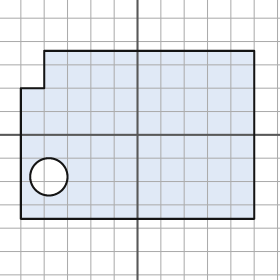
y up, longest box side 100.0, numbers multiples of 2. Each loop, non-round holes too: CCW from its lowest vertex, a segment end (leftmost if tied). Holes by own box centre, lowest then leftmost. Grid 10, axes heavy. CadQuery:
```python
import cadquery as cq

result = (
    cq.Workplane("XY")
    .moveTo(-50.0, -36.0)
    .lineTo(50.0, -36.0)
    .lineTo(50.0, 36.0)
    .lineTo(-40.0, 36.0)
    .lineTo(-40.0, 20.0)
    .lineTo(-50.0, 20.0)
    .close()
    .moveTo(-38.0, -18.0)
    .circle(8.0)
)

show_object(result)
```